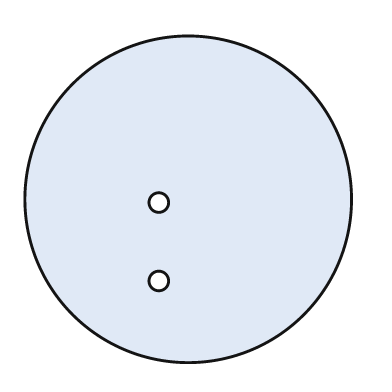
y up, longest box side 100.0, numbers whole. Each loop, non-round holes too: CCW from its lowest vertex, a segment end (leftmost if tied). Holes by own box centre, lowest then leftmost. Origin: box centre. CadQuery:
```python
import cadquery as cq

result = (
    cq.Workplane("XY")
    .moveTo(0.0, 0.0)
    .circle(50.0)
    .moveTo(-9.0, -25.0)
    .circle(3.0)
    .moveTo(-9.0, -1.0)
    .circle(3.0)
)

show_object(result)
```